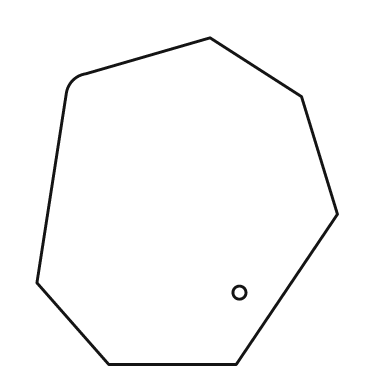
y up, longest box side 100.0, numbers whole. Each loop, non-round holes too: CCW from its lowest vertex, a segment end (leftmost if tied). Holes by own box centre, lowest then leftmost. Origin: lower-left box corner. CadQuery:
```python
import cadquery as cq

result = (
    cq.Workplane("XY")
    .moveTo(22.0, 0.0)
    .lineTo(61.0, 0.0)
    .lineTo(92.0, 46.0)
    .lineTo(81.0, 82.0)
    .lineTo(53.0, 100.0)
    .lineTo(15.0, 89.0)
    .threePointArc((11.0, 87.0), (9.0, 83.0))
    .lineTo(0.0, 25.0)
    .close()
    .moveTo(62.0, 22.0)
    .circle(2.0)
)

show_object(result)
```